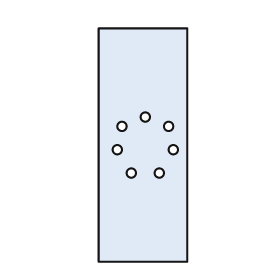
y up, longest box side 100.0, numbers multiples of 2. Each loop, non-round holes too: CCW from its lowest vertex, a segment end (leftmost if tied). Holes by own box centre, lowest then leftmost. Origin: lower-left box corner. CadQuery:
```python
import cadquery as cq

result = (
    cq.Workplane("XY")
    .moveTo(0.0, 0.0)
    .lineTo(38.0, 0.0)
    .lineTo(38.0, 100.0)
    .lineTo(0.0, 100.0)
    .close()
    .moveTo(14.0, 38.0)
    .circle(2.0)
    .moveTo(26.0, 38.0)
    .circle(2.0)
    .moveTo(8.0, 48.0)
    .circle(2.0)
    .moveTo(32.0, 48.0)
    .circle(2.0)
    .moveTo(10.0, 58.0)
    .circle(2.0)
    .moveTo(30.0, 58.0)
    .circle(2.0)
    .moveTo(20.0, 62.0)
    .circle(2.0)
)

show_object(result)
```